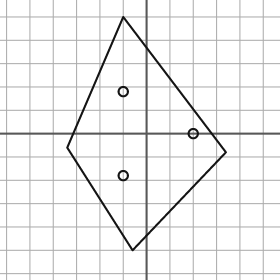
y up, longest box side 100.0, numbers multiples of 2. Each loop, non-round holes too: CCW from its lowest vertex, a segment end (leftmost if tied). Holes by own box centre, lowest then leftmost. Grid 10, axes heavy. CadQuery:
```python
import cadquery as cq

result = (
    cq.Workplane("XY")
    .moveTo(-6.0, -50.0)
    .lineTo(34.0, -8.0)
    .lineTo(-10.0, 50.0)
    .lineTo(-34.0, -6.0)
    .close()
    .moveTo(-10.0, -18.0)
    .circle(2.0)
    .moveTo(20.0, 0.0)
    .circle(2.0)
    .moveTo(-10.0, 18.0)
    .circle(2.0)
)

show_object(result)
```